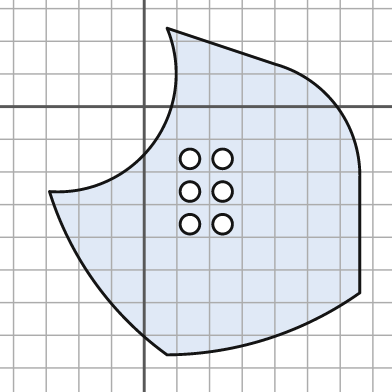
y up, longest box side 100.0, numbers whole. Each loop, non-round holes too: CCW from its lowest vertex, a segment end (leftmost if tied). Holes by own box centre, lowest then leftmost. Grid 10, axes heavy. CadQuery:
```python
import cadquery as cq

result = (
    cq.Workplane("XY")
    .moveTo(7.0, -76.0)
    .threePointArc((38.0, -71.0), (66.0, -57.0))
    .lineTo(66.0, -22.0)
    .threePointArc((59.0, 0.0), (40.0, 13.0))
    .lineTo(7.0, 24.0)
    .threePointArc((3.0, -11.0), (-29.0, -26.0))
    .threePointArc((-15.0, -54.0), (7.0, -76.0))
    .close()
    .moveTo(14.0, -36.0)
    .circle(3.0)
    .moveTo(24.0, -36.0)
    .circle(3.0)
    .moveTo(14.0, -26.0)
    .circle(3.0)
    .moveTo(24.0, -26.0)
    .circle(3.0)
    .moveTo(14.0, -16.0)
    .circle(3.0)
    .moveTo(24.0, -16.0)
    .circle(3.0)
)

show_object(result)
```